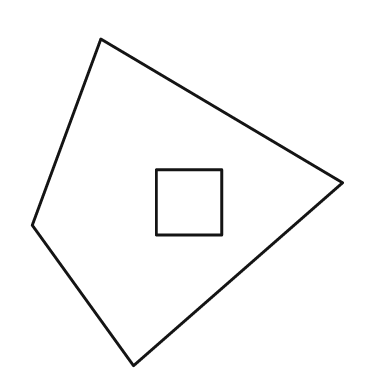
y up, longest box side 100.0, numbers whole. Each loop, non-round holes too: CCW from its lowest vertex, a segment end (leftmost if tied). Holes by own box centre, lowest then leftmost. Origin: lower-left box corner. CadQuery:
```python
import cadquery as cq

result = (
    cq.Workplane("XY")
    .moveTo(31.0, 0.0)
    .lineTo(95.0, 56.0)
    .lineTo(21.0, 100.0)
    .lineTo(0.0, 43.0)
    .close()
    .moveTo(38.0, 40.0)
    .lineTo(58.0, 40.0)
    .lineTo(58.0, 60.0)
    .lineTo(38.0, 60.0)
    .close()
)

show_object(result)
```